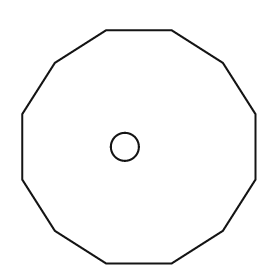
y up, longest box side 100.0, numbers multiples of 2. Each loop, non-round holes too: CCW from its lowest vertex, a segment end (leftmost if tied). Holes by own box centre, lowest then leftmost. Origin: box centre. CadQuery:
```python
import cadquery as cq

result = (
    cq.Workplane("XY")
    .moveTo(-14.0, -50.0)
    .lineTo(14.0, -50.0)
    .lineTo(36.0, -36.0)
    .lineTo(50.0, -14.0)
    .lineTo(50.0, 14.0)
    .lineTo(36.0, 36.0)
    .lineTo(14.0, 50.0)
    .lineTo(-14.0, 50.0)
    .lineTo(-36.0, 36.0)
    .lineTo(-50.0, 14.0)
    .lineTo(-50.0, -14.0)
    .lineTo(-36.0, -36.0)
    .close()
    .moveTo(-6.0, 0.0)
    .circle(6.0)
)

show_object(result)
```